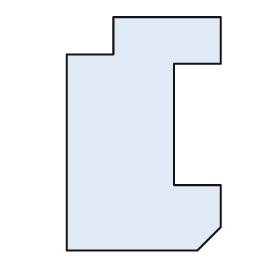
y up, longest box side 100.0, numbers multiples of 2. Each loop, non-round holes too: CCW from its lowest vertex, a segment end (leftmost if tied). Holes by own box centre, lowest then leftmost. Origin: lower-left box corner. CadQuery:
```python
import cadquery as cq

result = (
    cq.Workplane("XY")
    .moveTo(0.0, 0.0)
    .lineTo(56.0, 0.0)
    .lineTo(66.0, 10.0)
    .lineTo(66.0, 28.0)
    .lineTo(46.0, 28.0)
    .lineTo(46.0, 80.0)
    .lineTo(66.0, 80.0)
    .lineTo(66.0, 100.0)
    .lineTo(20.0, 100.0)
    .lineTo(20.0, 84.0)
    .lineTo(0.0, 84.0)
    .close()
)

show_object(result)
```